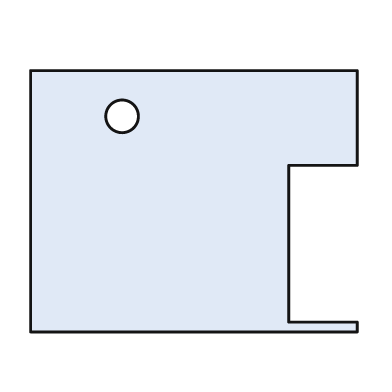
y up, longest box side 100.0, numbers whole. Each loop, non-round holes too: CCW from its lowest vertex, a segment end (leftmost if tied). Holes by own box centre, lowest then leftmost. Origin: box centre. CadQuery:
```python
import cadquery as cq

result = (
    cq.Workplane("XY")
    .moveTo(-50.0, -40.0)
    .lineTo(50.0, -40.0)
    .lineTo(50.0, -37.0)
    .lineTo(29.0, -37.0)
    .lineTo(29.0, 11.0)
    .lineTo(50.0, 11.0)
    .lineTo(50.0, 40.0)
    .lineTo(-50.0, 40.0)
    .close()
    .moveTo(-22.0, 26.0)
    .circle(5.0)
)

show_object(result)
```